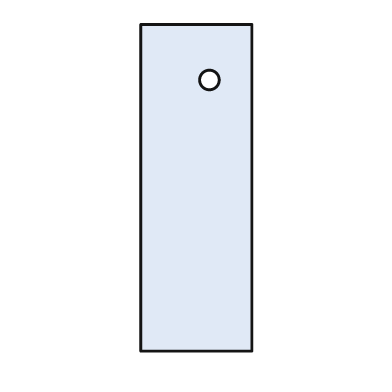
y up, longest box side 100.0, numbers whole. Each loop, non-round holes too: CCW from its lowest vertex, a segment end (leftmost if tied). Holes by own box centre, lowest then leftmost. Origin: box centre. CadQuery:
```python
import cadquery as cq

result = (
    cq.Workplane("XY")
    .moveTo(-17.0, -50.0)
    .lineTo(17.0, -50.0)
    .lineTo(17.0, 50.0)
    .lineTo(-17.0, 50.0)
    .close()
    .moveTo(4.0, 33.0)
    .circle(3.0)
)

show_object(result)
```